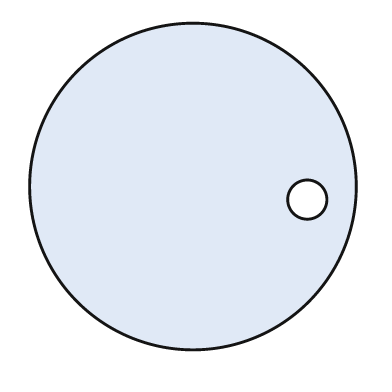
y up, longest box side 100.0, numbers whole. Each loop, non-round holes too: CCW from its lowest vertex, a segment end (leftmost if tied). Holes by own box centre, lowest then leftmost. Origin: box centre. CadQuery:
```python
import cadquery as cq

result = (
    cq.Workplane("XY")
    .moveTo(0.0, 0.0)
    .circle(50.0)
    .moveTo(35.0, -4.0)
    .circle(6.0)
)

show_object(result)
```